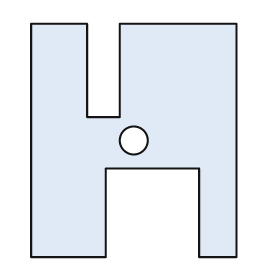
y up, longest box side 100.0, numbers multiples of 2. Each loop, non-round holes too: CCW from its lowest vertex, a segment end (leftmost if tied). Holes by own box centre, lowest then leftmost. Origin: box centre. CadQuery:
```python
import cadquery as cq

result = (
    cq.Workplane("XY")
    .moveTo(-44.0, -50.0)
    .lineTo(-12.0, -50.0)
    .lineTo(-12.0, -12.0)
    .lineTo(28.0, -12.0)
    .lineTo(28.0, -50.0)
    .lineTo(44.0, -50.0)
    .lineTo(44.0, 50.0)
    .lineTo(-6.0, 50.0)
    .lineTo(-6.0, 10.0)
    .lineTo(-20.0, 10.0)
    .lineTo(-20.0, 50.0)
    .lineTo(-44.0, 50.0)
    .close()
    .moveTo(0.0, 0.0)
    .circle(6.0)
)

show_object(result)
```